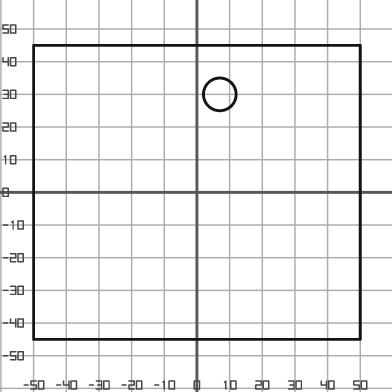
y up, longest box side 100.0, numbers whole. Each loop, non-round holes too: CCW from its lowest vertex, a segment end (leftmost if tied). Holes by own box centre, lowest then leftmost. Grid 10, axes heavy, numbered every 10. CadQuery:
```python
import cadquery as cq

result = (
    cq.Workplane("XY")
    .moveTo(-50.0, -45.0)
    .lineTo(50.0, -45.0)
    .lineTo(50.0, 45.0)
    .lineTo(-50.0, 45.0)
    .close()
    .moveTo(7.0, 30.0)
    .circle(5.0)
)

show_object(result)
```